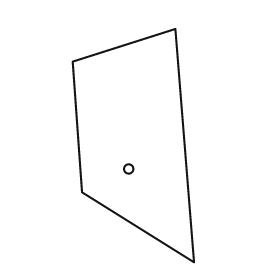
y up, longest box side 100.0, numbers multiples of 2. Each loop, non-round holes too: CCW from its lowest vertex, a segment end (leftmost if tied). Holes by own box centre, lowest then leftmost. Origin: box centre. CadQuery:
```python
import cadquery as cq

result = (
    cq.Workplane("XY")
    .moveTo(26.0, -50.0)
    .lineTo(18.0, 50.0)
    .lineTo(-26.0, 36.0)
    .lineTo(-22.0, -20.0)
    .close()
    .moveTo(-2.0, -10.0)
    .circle(2.0)
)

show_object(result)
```